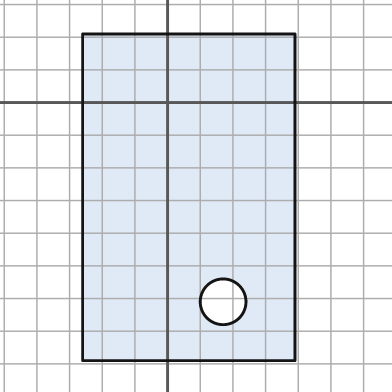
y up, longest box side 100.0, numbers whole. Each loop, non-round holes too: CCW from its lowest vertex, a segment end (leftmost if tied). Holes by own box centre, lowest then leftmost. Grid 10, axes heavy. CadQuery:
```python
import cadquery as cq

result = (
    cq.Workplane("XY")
    .moveTo(-26.0, -79.0)
    .lineTo(39.0, -79.0)
    .lineTo(39.0, 21.0)
    .lineTo(-26.0, 21.0)
    .close()
    .moveTo(17.0, -61.0)
    .circle(7.0)
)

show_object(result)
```